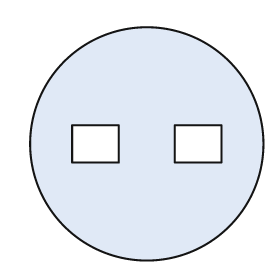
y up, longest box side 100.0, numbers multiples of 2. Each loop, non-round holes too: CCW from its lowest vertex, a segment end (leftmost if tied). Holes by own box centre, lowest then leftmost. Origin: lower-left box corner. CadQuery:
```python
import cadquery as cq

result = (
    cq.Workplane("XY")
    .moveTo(50.0, 50.0)
    .circle(50.0)
    .moveTo(18.0, 42.0)
    .lineTo(38.0, 42.0)
    .lineTo(38.0, 58.0)
    .lineTo(18.0, 58.0)
    .close()
    .moveTo(62.0, 42.0)
    .lineTo(82.0, 42.0)
    .lineTo(82.0, 58.0)
    .lineTo(62.0, 58.0)
    .close()
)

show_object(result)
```